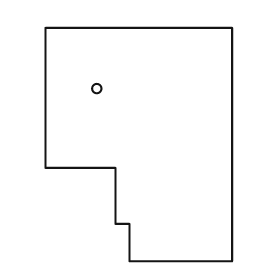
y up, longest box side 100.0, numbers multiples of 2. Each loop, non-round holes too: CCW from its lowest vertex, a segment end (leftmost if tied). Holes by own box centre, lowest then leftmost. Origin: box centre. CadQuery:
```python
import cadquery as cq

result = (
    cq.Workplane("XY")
    .moveTo(-4.0, -50.0)
    .lineTo(40.0, -50.0)
    .lineTo(40.0, 50.0)
    .lineTo(-40.0, 50.0)
    .lineTo(-40.0, -10.0)
    .lineTo(-10.0, -10.0)
    .lineTo(-10.0, -34.0)
    .lineTo(-4.0, -34.0)
    .close()
    .moveTo(-18.0, 24.0)
    .circle(2.0)
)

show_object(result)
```